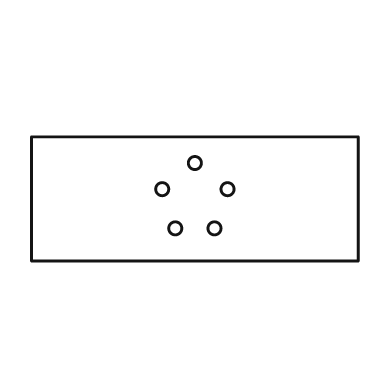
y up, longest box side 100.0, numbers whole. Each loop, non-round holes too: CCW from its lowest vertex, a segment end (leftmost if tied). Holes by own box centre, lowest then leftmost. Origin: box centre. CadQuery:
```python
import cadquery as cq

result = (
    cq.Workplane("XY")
    .moveTo(-50.0, -19.0)
    .lineTo(50.0, -19.0)
    .lineTo(50.0, 19.0)
    .lineTo(-50.0, 19.0)
    .close()
    .moveTo(-6.0, -9.0)
    .circle(2.0)
    .moveTo(6.0, -9.0)
    .circle(2.0)
    .moveTo(-10.0, 3.0)
    .circle(2.0)
    .moveTo(10.0, 3.0)
    .circle(2.0)
    .moveTo(0.0, 11.0)
    .circle(2.0)
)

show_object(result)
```